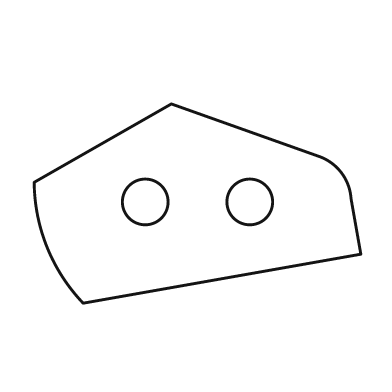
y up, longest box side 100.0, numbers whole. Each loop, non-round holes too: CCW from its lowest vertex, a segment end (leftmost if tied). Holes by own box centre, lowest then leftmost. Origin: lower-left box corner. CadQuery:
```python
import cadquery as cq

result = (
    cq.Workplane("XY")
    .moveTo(15.0, 0.0)
    .lineTo(100.0, 15.0)
    .lineTo(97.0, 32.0)
    .threePointArc((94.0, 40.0), (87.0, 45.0))
    .lineTo(42.0, 61.0)
    .lineTo(0.0, 37.0)
    .threePointArc((4.0, 17.0), (15.0, 0.0))
    .close()
    .moveTo(34.0, 31.0)
    .circle(7.0)
    .moveTo(66.0, 31.0)
    .circle(7.0)
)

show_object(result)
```